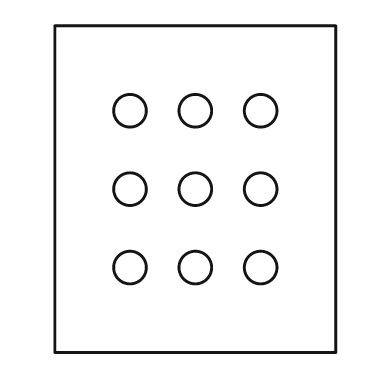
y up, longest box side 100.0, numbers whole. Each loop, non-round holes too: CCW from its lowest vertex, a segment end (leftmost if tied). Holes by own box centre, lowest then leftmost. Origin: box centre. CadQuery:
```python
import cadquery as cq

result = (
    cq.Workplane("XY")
    .moveTo(-43.0, -50.0)
    .lineTo(43.0, -50.0)
    .lineTo(43.0, 50.0)
    .lineTo(-43.0, 50.0)
    .close()
    .moveTo(-20.0, -24.0)
    .circle(5.0)
    .moveTo(0.0, -24.0)
    .circle(5.0)
    .moveTo(20.0, -24.0)
    .circle(5.0)
    .moveTo(-20.0, 0.0)
    .circle(5.0)
    .moveTo(0.0, 0.0)
    .circle(5.0)
    .moveTo(20.0, 0.0)
    .circle(5.0)
    .moveTo(-20.0, 24.0)
    .circle(5.0)
    .moveTo(0.0, 24.0)
    .circle(5.0)
    .moveTo(20.0, 24.0)
    .circle(5.0)
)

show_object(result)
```